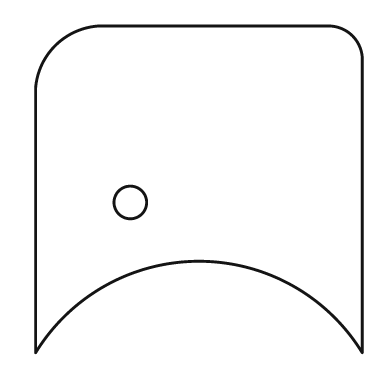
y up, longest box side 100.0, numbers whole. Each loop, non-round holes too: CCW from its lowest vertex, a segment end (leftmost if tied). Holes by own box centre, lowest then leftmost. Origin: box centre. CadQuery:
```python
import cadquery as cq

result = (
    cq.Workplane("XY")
    .moveTo(-50.0, -50.0)
    .threePointArc((0.0, -22.0), (50.0, -50.0))
    .lineTo(50.0, 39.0)
    .threePointArc((47.0, 47.0), (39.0, 50.0))
    .lineTo(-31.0, 50.0)
    .threePointArc((-44.0, 44.0), (-50.0, 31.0))
    .close()
    .moveTo(-21.0, -4.0)
    .circle(5.0)
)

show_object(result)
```